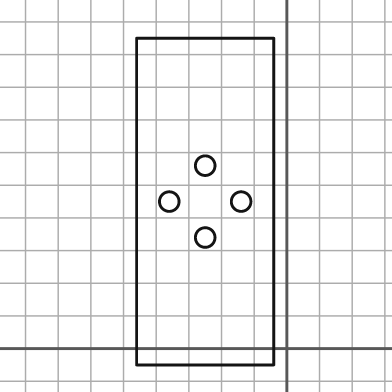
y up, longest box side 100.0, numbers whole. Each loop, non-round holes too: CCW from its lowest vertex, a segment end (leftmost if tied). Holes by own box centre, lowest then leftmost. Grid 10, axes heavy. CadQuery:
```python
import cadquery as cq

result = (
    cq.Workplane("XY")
    .moveTo(-46.0, -5.0)
    .lineTo(-4.0, -5.0)
    .lineTo(-4.0, 95.0)
    .lineTo(-46.0, 95.0)
    .close()
    .moveTo(-25.0, 34.0)
    .circle(3.0)
    .moveTo(-36.0, 45.0)
    .circle(3.0)
    .moveTo(-14.0, 45.0)
    .circle(3.0)
    .moveTo(-25.0, 56.0)
    .circle(3.0)
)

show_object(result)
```